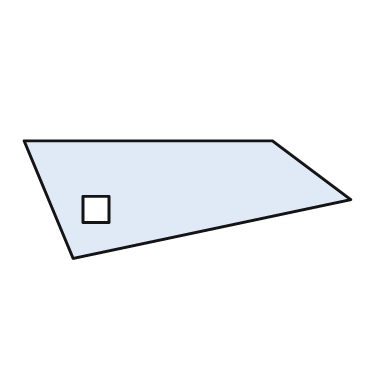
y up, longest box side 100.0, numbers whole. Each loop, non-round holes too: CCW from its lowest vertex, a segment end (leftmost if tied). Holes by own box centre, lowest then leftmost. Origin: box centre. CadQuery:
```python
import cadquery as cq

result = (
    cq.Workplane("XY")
    .moveTo(-35.0, -18.0)
    .lineTo(50.0, 0.0)
    .lineTo(26.0, 18.0)
    .lineTo(-50.0, 18.0)
    .close()
    .moveTo(-32.0, -7.0)
    .lineTo(-24.0, -7.0)
    .lineTo(-24.0, 1.0)
    .lineTo(-32.0, 1.0)
    .close()
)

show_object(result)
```